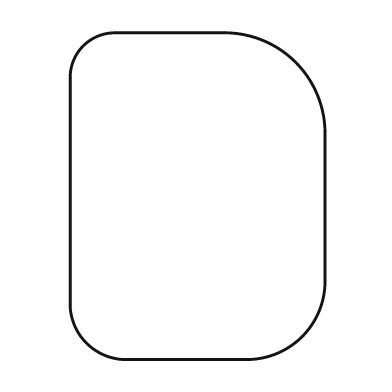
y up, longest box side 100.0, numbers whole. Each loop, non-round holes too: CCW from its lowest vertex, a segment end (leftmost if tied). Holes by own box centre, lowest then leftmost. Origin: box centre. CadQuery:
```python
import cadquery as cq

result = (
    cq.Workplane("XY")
    .moveTo(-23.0, -50.0)
    .lineTo(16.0, -50.0)
    .threePointArc((32.0, -43.0), (39.0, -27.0))
    .lineTo(39.0, 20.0)
    .threePointArc((30.0, 41.0), (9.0, 50.0))
    .lineTo(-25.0, 50.0)
    .threePointArc((-35.0, 46.0), (-39.0, 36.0))
    .lineTo(-39.0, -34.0)
    .threePointArc((-34.0, -45.0), (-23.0, -50.0))
    .close()
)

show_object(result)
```